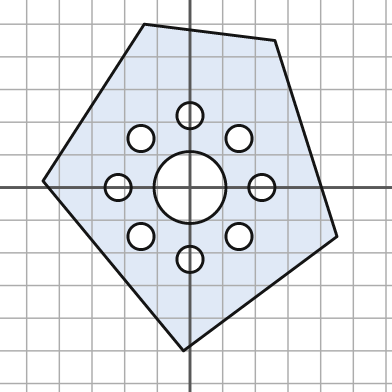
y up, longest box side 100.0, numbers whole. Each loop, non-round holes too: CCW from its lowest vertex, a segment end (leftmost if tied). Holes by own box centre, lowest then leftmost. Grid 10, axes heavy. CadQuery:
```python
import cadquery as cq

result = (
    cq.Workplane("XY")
    .moveTo(-2.0, -50.0)
    .lineTo(45.0, -15.0)
    .lineTo(26.0, 45.0)
    .lineTo(-14.0, 50.0)
    .lineTo(-45.0, 2.0)
    .close()
    .moveTo(0.0, -22.0)
    .circle(4.0)
    .moveTo(-15.0, -15.0)
    .circle(4.0)
    .moveTo(15.0, -15.0)
    .circle(4.0)
    .moveTo(-22.0, 0.0)
    .circle(4.0)
    .moveTo(0.0, 0.0)
    .circle(11.0)
    .moveTo(22.0, 0.0)
    .circle(4.0)
    .moveTo(-15.0, 15.0)
    .circle(4.0)
    .moveTo(15.0, 15.0)
    .circle(4.0)
    .moveTo(0.0, 22.0)
    .circle(4.0)
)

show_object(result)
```